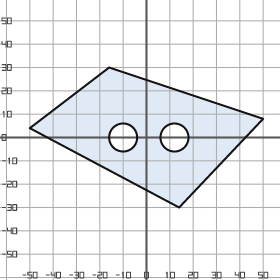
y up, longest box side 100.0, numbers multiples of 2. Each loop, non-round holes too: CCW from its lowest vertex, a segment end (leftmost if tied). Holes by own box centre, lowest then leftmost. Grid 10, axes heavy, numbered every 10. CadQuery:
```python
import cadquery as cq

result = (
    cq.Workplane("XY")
    .moveTo(14.0, -30.0)
    .lineTo(50.0, 8.0)
    .lineTo(-16.0, 30.0)
    .lineTo(-50.0, 4.0)
    .close()
    .moveTo(-10.0, 0.0)
    .circle(6.0)
    .moveTo(12.0, 0.0)
    .circle(6.0)
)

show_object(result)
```